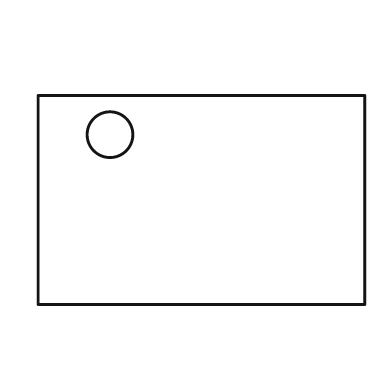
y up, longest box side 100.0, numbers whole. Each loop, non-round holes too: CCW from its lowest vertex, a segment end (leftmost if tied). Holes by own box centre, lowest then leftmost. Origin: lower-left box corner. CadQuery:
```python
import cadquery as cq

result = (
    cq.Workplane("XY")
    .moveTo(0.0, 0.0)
    .lineTo(100.0, 0.0)
    .lineTo(100.0, 64.0)
    .lineTo(0.0, 64.0)
    .close()
    .moveTo(22.0, 52.0)
    .circle(7.0)
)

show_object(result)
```